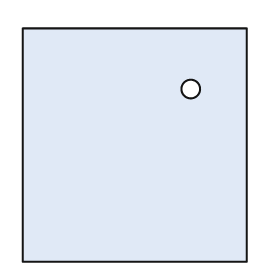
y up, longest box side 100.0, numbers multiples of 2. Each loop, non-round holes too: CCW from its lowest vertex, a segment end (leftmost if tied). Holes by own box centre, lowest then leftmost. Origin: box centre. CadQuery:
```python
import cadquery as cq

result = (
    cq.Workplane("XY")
    .moveTo(-48.0, -50.0)
    .lineTo(48.0, -50.0)
    .lineTo(48.0, 50.0)
    .lineTo(-48.0, 50.0)
    .close()
    .moveTo(24.0, 24.0)
    .circle(4.0)
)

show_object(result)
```